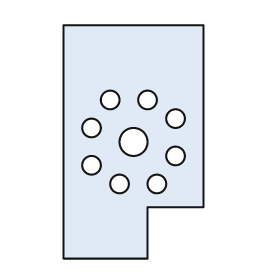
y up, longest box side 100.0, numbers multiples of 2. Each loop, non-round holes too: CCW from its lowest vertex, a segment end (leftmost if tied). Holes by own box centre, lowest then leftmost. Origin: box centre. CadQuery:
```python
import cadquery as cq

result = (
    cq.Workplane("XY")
    .moveTo(-30.0, -50.0)
    .lineTo(6.0, -50.0)
    .lineTo(6.0, -28.0)
    .lineTo(30.0, -28.0)
    .lineTo(30.0, 50.0)
    .lineTo(-30.0, 50.0)
    .close()
    .moveTo(-6.0, -18.0)
    .circle(4.0)
    .moveTo(10.0, -18.0)
    .circle(4.0)
    .moveTo(-18.0, -10.0)
    .circle(4.0)
    .moveTo(18.0, -6.0)
    .circle(4.0)
    .moveTo(0.0, 0.0)
    .circle(6.0)
    .moveTo(-18.0, 6.0)
    .circle(4.0)
    .moveTo(18.0, 10.0)
    .circle(4.0)
    .moveTo(-10.0, 18.0)
    .circle(4.0)
    .moveTo(6.0, 18.0)
    .circle(4.0)
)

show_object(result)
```